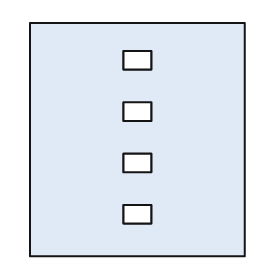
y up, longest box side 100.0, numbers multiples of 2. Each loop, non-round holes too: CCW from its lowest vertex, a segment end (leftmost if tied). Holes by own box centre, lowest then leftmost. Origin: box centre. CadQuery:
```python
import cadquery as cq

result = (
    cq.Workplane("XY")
    .moveTo(-46.0, -50.0)
    .lineTo(46.0, -50.0)
    .lineTo(46.0, 50.0)
    .lineTo(-46.0, 50.0)
    .close()
    .moveTo(-6.0, -36.0)
    .lineTo(6.0, -36.0)
    .lineTo(6.0, -28.0)
    .lineTo(-6.0, -28.0)
    .close()
    .moveTo(-6.0, -14.0)
    .lineTo(6.0, -14.0)
    .lineTo(6.0, -6.0)
    .lineTo(-6.0, -6.0)
    .close()
    .moveTo(-6.0, 8.0)
    .lineTo(6.0, 8.0)
    .lineTo(6.0, 16.0)
    .lineTo(-6.0, 16.0)
    .close()
    .moveTo(-6.0, 30.0)
    .lineTo(6.0, 30.0)
    .lineTo(6.0, 38.0)
    .lineTo(-6.0, 38.0)
    .close()
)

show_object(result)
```